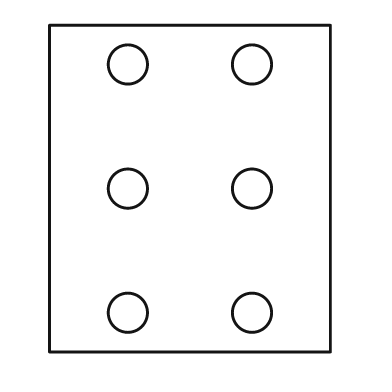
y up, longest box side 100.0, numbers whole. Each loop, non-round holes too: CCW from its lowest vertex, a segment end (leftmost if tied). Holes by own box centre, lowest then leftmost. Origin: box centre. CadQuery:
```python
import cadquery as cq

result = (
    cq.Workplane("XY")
    .moveTo(-43.0, -50.0)
    .lineTo(43.0, -50.0)
    .lineTo(43.0, 50.0)
    .lineTo(-43.0, 50.0)
    .close()
    .moveTo(-19.0, -38.0)
    .circle(6.0)
    .moveTo(19.0, -38.0)
    .circle(6.0)
    .moveTo(-19.0, 0.0)
    .circle(6.0)
    .moveTo(19.0, 0.0)
    .circle(6.0)
    .moveTo(-19.0, 38.0)
    .circle(6.0)
    .moveTo(19.0, 38.0)
    .circle(6.0)
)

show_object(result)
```